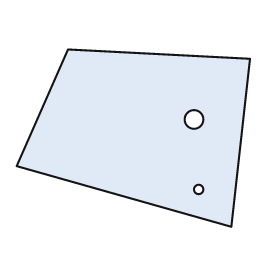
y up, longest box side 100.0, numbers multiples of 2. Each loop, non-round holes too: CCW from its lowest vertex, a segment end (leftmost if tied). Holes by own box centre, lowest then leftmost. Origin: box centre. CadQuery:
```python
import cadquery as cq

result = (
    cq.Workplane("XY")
    .moveTo(42.0, -38.0)
    .lineTo(50.0, 34.0)
    .lineTo(-28.0, 38.0)
    .lineTo(-50.0, -12.0)
    .close()
    .moveTo(28.0, -22.0)
    .circle(2.0)
    .moveTo(26.0, 8.0)
    .circle(4.0)
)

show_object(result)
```